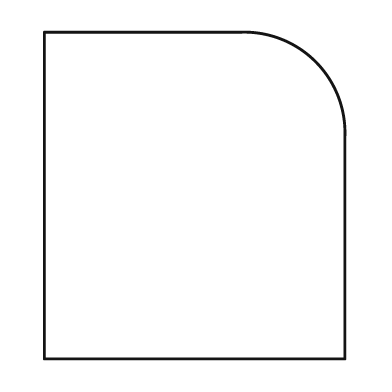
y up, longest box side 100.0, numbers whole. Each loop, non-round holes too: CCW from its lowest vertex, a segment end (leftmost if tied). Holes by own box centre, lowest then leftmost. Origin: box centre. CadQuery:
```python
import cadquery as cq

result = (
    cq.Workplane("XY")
    .moveTo(-46.0, -50.0)
    .lineTo(46.0, -50.0)
    .lineTo(46.0, 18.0)
    .threePointArc((37.0, 41.0), (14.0, 50.0))
    .lineTo(-46.0, 50.0)
    .close()
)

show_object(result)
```